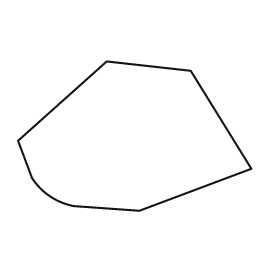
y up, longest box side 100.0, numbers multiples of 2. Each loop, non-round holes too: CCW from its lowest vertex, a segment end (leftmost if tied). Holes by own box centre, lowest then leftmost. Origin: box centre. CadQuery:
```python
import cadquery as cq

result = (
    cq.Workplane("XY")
    .moveTo(2.0, -32.0)
    .lineTo(50.0, -14.0)
    .lineTo(24.0, 28.0)
    .lineTo(-12.0, 32.0)
    .lineTo(-50.0, -2.0)
    .lineTo(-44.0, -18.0)
    .threePointArc((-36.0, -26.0), (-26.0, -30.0))
    .close()
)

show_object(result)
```